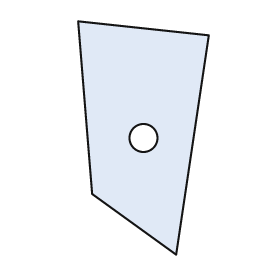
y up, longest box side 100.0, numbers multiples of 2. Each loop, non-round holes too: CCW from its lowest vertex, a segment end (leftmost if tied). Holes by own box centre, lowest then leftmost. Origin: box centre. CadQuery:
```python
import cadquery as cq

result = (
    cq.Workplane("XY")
    .moveTo(14.0, -50.0)
    .lineTo(28.0, 44.0)
    .lineTo(-28.0, 50.0)
    .lineTo(-22.0, -24.0)
    .close()
    .moveTo(0.0, 0.0)
    .circle(6.0)
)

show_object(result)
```